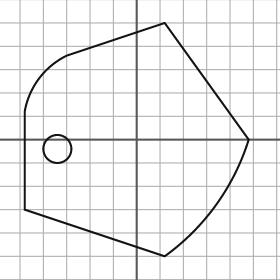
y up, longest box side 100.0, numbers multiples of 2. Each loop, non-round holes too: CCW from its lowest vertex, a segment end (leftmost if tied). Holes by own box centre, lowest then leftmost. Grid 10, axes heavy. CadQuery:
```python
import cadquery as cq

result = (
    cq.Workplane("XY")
    .moveTo(12.0, -50.0)
    .threePointArc((34.0, -28.0), (48.0, 0.0))
    .lineTo(12.0, 50.0)
    .lineTo(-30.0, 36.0)
    .threePointArc((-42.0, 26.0), (-48.0, 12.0))
    .lineTo(-48.0, -30.0)
    .close()
    .moveTo(-34.0, -4.0)
    .circle(6.0)
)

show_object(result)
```